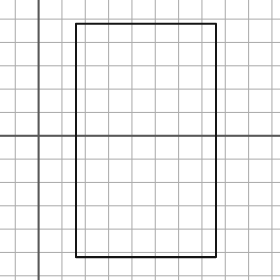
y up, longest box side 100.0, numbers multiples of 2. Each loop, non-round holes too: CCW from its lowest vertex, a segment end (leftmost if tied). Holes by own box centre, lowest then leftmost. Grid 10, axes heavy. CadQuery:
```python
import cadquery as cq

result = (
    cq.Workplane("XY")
    .moveTo(16.0, -52.0)
    .lineTo(76.0, -52.0)
    .lineTo(76.0, 48.0)
    .lineTo(16.0, 48.0)
    .close()
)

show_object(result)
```